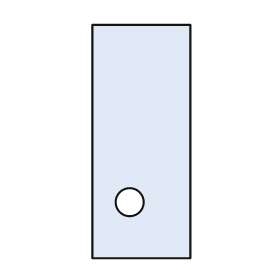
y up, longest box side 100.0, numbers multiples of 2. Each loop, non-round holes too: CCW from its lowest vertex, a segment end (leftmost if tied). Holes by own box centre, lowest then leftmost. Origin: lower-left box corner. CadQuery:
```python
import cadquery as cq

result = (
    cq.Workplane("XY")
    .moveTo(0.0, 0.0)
    .lineTo(42.0, 0.0)
    .lineTo(42.0, 100.0)
    .lineTo(0.0, 100.0)
    .close()
    .moveTo(16.0, 24.0)
    .circle(6.0)
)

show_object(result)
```